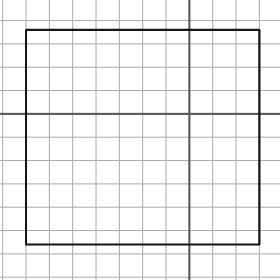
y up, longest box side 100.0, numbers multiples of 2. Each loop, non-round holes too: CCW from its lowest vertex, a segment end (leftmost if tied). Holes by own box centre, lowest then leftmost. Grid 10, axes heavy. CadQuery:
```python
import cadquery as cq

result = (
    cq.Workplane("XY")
    .moveTo(-70.0, -56.0)
    .lineTo(30.0, -56.0)
    .lineTo(30.0, 36.0)
    .lineTo(-70.0, 36.0)
    .close()
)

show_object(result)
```